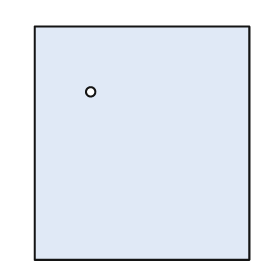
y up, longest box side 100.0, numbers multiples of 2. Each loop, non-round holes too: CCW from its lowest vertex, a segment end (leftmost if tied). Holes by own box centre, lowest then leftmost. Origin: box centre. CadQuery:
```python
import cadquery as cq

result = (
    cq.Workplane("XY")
    .moveTo(-46.0, -50.0)
    .lineTo(46.0, -50.0)
    .lineTo(46.0, 50.0)
    .lineTo(-46.0, 50.0)
    .close()
    .moveTo(-22.0, 22.0)
    .circle(2.0)
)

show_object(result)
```